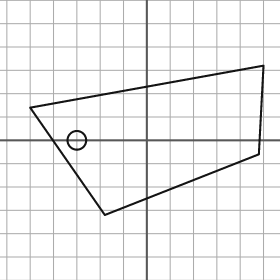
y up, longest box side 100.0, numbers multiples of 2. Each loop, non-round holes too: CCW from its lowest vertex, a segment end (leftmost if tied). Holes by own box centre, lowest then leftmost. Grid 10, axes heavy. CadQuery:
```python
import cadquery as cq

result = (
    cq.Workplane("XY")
    .moveTo(-18.0, -32.0)
    .lineTo(48.0, -6.0)
    .lineTo(50.0, 32.0)
    .lineTo(-50.0, 14.0)
    .close()
    .moveTo(-30.0, 0.0)
    .circle(4.0)
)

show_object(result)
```